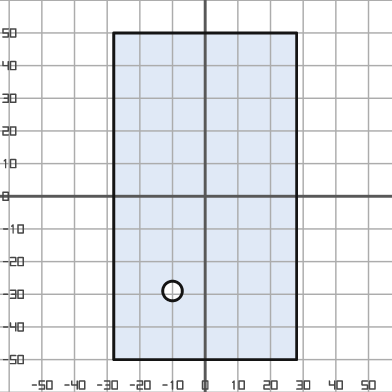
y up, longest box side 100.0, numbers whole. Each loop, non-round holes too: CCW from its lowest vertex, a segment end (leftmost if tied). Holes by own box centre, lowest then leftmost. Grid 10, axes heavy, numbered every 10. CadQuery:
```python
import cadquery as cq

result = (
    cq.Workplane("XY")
    .moveTo(-28.0, -50.0)
    .lineTo(28.0, -50.0)
    .lineTo(28.0, 50.0)
    .lineTo(-28.0, 50.0)
    .close()
    .moveTo(-10.0, -29.0)
    .circle(3.0)
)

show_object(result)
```